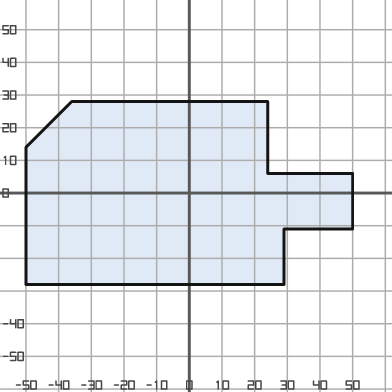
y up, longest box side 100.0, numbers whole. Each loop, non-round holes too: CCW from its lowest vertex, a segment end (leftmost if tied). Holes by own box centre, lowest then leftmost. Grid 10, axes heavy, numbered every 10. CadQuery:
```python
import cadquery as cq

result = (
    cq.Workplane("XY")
    .moveTo(-50.0, -28.0)
    .lineTo(29.0, -28.0)
    .lineTo(29.0, -11.0)
    .lineTo(50.0, -11.0)
    .lineTo(50.0, 6.0)
    .lineTo(24.0, 6.0)
    .lineTo(24.0, 28.0)
    .lineTo(-36.0, 28.0)
    .lineTo(-50.0, 14.0)
    .close()
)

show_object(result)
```